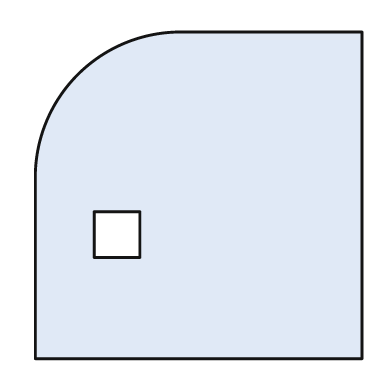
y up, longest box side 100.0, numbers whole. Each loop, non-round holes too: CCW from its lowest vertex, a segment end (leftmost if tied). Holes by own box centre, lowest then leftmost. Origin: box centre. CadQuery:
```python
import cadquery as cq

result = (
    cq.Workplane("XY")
    .moveTo(-50.0, -50.0)
    .lineTo(50.0, -50.0)
    .lineTo(50.0, 50.0)
    .lineTo(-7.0, 50.0)
    .threePointArc((-37.0, 37.0), (-50.0, 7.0))
    .close()
    .moveTo(-32.0, -19.0)
    .lineTo(-18.0, -19.0)
    .lineTo(-18.0, -5.0)
    .lineTo(-32.0, -5.0)
    .close()
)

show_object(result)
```